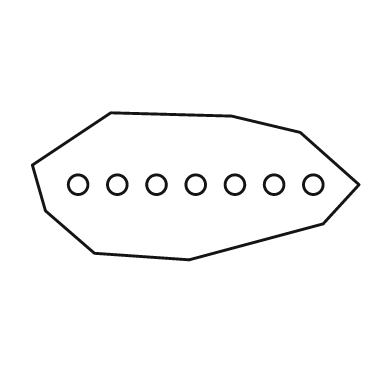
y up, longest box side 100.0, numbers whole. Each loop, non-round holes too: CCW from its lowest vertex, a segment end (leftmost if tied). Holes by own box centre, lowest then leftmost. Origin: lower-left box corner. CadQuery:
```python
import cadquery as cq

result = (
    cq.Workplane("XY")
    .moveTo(48.0, 0.0)
    .lineTo(89.0, 11.0)
    .lineTo(100.0, 23.0)
    .lineTo(82.0, 39.0)
    .lineTo(61.0, 44.0)
    .lineTo(24.0, 45.0)
    .lineTo(0.0, 29.0)
    .lineTo(4.0, 15.0)
    .lineTo(19.0, 2.0)
    .close()
    .moveTo(14.0, 23.0)
    .circle(3.0)
    .moveTo(26.0, 23.0)
    .circle(3.0)
    .moveTo(38.0, 23.0)
    .circle(3.0)
    .moveTo(50.0, 23.0)
    .circle(3.0)
    .moveTo(62.0, 23.0)
    .circle(3.0)
    .moveTo(74.0, 23.0)
    .circle(3.0)
    .moveTo(86.0, 23.0)
    .circle(3.0)
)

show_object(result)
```